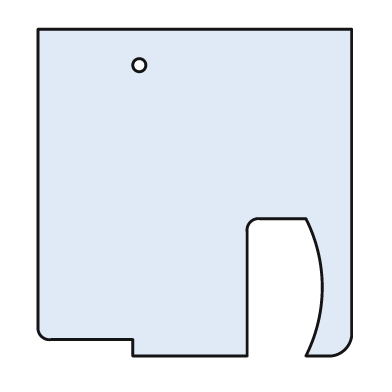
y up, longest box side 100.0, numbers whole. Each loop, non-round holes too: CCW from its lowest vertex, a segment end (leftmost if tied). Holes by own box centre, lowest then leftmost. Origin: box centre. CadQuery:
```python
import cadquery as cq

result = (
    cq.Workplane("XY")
    .moveTo(-19.0, -50.0)
    .lineTo(16.0, -50.0)
    .lineTo(16.0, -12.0)
    .threePointArc((17.0, -9.0), (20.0, -8.0))
    .lineTo(34.0, -8.0)
    .threePointArc((39.0, -29.0), (34.0, -50.0))
    .lineTo(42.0, -50.0)
    .threePointArc((46.0, -48.0), (48.0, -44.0))
    .lineTo(48.0, 50.0)
    .lineTo(-48.0, 50.0)
    .lineTo(-48.0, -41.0)
    .threePointArc((-47.0, -44.0), (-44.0, -45.0))
    .lineTo(-19.0, -45.0)
    .close()
    .moveTo(-17.0, 39.0)
    .circle(2.0)
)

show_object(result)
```